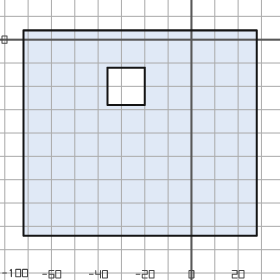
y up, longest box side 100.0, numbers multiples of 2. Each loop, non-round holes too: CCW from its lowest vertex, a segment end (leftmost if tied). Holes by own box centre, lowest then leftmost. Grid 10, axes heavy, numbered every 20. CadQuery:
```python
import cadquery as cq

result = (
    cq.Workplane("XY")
    .moveTo(-72.0, -84.0)
    .lineTo(28.0, -84.0)
    .lineTo(28.0, 4.0)
    .lineTo(-72.0, 4.0)
    .close()
    .moveTo(-36.0, -28.0)
    .lineTo(-20.0, -28.0)
    .lineTo(-20.0, -12.0)
    .lineTo(-36.0, -12.0)
    .close()
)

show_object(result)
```